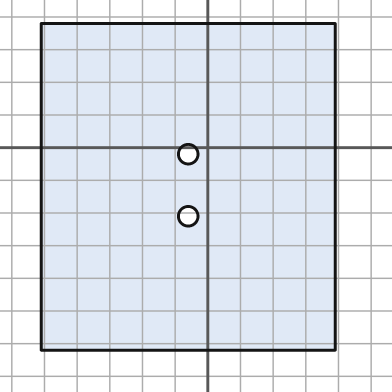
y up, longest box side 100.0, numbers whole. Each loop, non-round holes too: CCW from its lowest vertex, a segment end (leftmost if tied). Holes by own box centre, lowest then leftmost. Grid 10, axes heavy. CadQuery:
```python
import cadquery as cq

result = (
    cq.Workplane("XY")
    .moveTo(-51.0, -62.0)
    .lineTo(39.0, -62.0)
    .lineTo(39.0, 38.0)
    .lineTo(-51.0, 38.0)
    .close()
    .moveTo(-6.0, -21.0)
    .circle(3.0)
    .moveTo(-6.0, -2.0)
    .circle(3.0)
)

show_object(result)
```